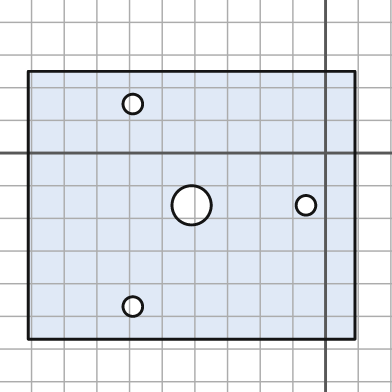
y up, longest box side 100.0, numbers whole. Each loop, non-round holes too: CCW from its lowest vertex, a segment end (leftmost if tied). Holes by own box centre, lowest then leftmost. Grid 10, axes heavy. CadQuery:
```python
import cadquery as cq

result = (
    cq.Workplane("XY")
    .moveTo(-91.0, -57.0)
    .lineTo(9.0, -57.0)
    .lineTo(9.0, 25.0)
    .lineTo(-91.0, 25.0)
    .close()
    .moveTo(-59.0, -47.0)
    .circle(3.0)
    .moveTo(-41.0, -16.0)
    .circle(6.0)
    .moveTo(-6.0, -16.0)
    .circle(3.0)
    .moveTo(-59.0, 15.0)
    .circle(3.0)
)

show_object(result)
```